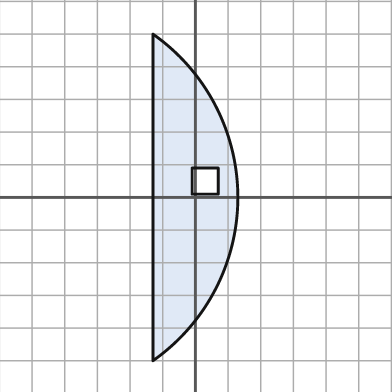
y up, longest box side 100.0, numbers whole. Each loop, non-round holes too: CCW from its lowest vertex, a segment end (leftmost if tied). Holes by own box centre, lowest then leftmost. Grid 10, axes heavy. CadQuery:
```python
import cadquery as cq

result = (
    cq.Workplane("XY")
    .moveTo(-13.0, -50.0)
    .threePointArc((13.0, 0.0), (-13.0, 50.0))
    .close()
    .moveTo(-1.0, 1.0)
    .lineTo(7.0, 1.0)
    .lineTo(7.0, 9.0)
    .lineTo(-1.0, 9.0)
    .close()
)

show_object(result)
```